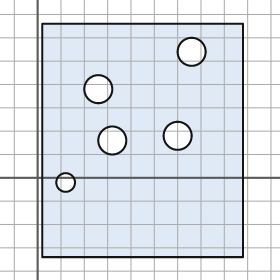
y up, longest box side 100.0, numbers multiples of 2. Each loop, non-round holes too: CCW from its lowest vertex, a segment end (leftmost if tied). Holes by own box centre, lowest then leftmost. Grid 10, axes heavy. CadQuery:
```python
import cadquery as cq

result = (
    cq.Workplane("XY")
    .moveTo(2.0, -34.0)
    .lineTo(88.0, -34.0)
    .lineTo(88.0, 66.0)
    .lineTo(2.0, 66.0)
    .close()
    .moveTo(12.0, -2.0)
    .circle(4.0)
    .moveTo(32.0, 16.0)
    .circle(6.0)
    .moveTo(60.0, 18.0)
    .circle(6.0)
    .moveTo(26.0, 38.0)
    .circle(6.0)
    .moveTo(66.0, 54.0)
    .circle(6.0)
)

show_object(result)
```